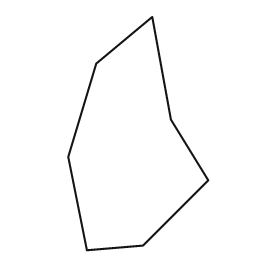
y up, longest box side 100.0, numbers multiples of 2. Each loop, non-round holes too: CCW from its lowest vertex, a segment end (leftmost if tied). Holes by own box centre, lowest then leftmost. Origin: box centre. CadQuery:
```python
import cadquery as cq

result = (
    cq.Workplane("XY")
    .moveTo(-22.0, -50.0)
    .lineTo(2.0, -48.0)
    .lineTo(30.0, -20.0)
    .lineTo(14.0, 6.0)
    .lineTo(6.0, 50.0)
    .lineTo(-18.0, 30.0)
    .lineTo(-30.0, -10.0)
    .close()
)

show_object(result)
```